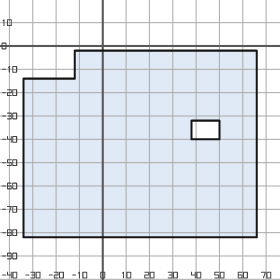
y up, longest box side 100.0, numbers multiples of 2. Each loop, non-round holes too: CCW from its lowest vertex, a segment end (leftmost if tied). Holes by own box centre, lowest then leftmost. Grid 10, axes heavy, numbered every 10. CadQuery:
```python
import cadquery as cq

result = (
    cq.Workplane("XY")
    .moveTo(-34.0, -82.0)
    .lineTo(66.0, -82.0)
    .lineTo(66.0, -2.0)
    .lineTo(-12.0, -2.0)
    .lineTo(-12.0, -14.0)
    .lineTo(-34.0, -14.0)
    .close()
    .moveTo(38.0, -40.0)
    .lineTo(50.0, -40.0)
    .lineTo(50.0, -32.0)
    .lineTo(38.0, -32.0)
    .close()
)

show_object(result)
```